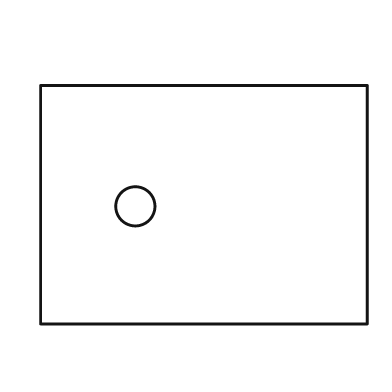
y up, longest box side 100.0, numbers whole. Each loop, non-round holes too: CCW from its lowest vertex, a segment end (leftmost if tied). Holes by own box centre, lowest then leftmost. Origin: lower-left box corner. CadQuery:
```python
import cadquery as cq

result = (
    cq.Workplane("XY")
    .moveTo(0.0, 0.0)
    .lineTo(100.0, 0.0)
    .lineTo(100.0, 73.0)
    .lineTo(0.0, 73.0)
    .close()
    .moveTo(29.0, 36.0)
    .circle(6.0)
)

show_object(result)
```